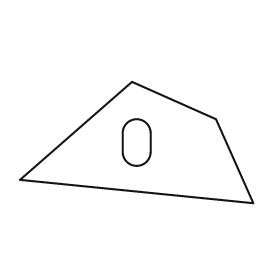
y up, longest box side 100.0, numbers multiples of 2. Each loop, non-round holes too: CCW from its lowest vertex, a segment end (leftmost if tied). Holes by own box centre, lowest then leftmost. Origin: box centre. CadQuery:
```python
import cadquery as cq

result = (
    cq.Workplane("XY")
    .moveTo(50.0, -26.0)
    .lineTo(34.0, 10.0)
    .lineTo(-2.0, 26.0)
    .lineTo(-50.0, -16.0)
    .close()
    .moveTo(-6.0, -4.0)
    .threePointArc((0.0, -10.0), (6.0, -4.0))
    .lineTo(6.0, 4.0)
    .threePointArc((0.0, 10.0), (-6.0, 4.0))
    .close()
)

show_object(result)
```